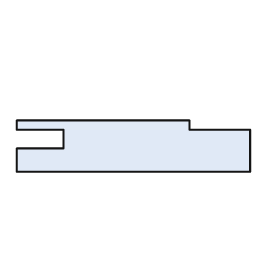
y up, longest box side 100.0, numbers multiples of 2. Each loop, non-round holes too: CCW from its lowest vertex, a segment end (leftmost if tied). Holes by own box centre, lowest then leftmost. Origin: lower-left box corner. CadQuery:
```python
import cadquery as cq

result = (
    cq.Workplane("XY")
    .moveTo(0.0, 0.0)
    .lineTo(100.0, 0.0)
    .lineTo(100.0, 18.0)
    .lineTo(74.0, 18.0)
    .lineTo(74.0, 22.0)
    .lineTo(0.0, 22.0)
    .lineTo(0.0, 18.0)
    .lineTo(20.0, 18.0)
    .lineTo(20.0, 10.0)
    .lineTo(0.0, 10.0)
    .close()
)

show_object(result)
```